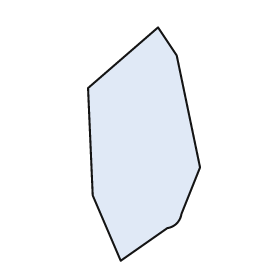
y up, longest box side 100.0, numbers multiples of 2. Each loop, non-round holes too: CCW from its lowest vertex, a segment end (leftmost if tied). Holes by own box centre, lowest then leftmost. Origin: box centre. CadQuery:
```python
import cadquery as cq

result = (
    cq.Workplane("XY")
    .moveTo(-10.0, -50.0)
    .lineTo(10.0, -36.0)
    .threePointArc((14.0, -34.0), (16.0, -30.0))
    .lineTo(24.0, -10.0)
    .lineTo(14.0, 38.0)
    .lineTo(6.0, 50.0)
    .lineTo(-24.0, 24.0)
    .lineTo(-22.0, -22.0)
    .close()
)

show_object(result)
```